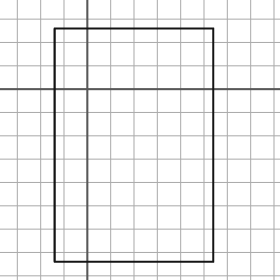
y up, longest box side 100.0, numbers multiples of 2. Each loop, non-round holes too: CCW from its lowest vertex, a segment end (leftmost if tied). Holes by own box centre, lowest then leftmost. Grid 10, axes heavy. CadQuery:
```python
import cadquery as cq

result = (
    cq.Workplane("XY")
    .moveTo(-14.0, -74.0)
    .lineTo(54.0, -74.0)
    .lineTo(54.0, 26.0)
    .lineTo(-14.0, 26.0)
    .close()
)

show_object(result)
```